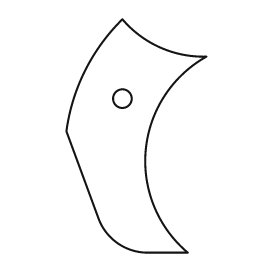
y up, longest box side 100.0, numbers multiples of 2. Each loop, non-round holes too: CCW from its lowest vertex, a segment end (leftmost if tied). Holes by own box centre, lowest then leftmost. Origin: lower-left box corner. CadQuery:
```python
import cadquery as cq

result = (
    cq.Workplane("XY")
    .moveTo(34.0, 0.0)
    .lineTo(52.0, 0.0)
    .threePointArc((34.0, 44.0), (60.0, 84.0))
    .threePointArc((40.0, 88.0), (24.0, 100.0))
    .threePointArc((8.0, 78.0), (0.0, 52.0))
    .lineTo(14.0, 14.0)
    .threePointArc((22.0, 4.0), (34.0, 0.0))
    .close()
    .moveTo(24.0, 66.0)
    .circle(4.0)
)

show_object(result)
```